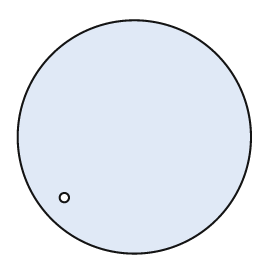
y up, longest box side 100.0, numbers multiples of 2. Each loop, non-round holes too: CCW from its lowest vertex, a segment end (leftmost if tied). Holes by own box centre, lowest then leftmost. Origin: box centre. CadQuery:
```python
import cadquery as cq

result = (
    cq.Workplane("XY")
    .moveTo(0.0, 0.0)
    .circle(50.0)
    .moveTo(-30.0, -26.0)
    .circle(2.0)
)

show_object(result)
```